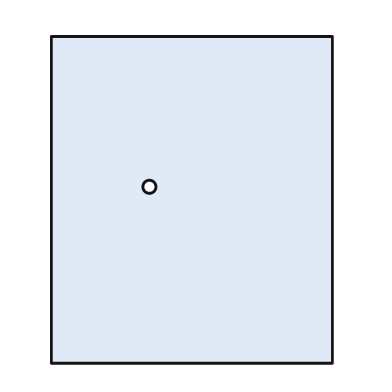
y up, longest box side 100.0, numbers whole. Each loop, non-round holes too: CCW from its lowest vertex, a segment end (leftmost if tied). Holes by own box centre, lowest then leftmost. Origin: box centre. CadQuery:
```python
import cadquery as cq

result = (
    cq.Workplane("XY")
    .moveTo(-43.0, -50.0)
    .lineTo(43.0, -50.0)
    .lineTo(43.0, 50.0)
    .lineTo(-43.0, 50.0)
    .close()
    .moveTo(-13.0, 4.0)
    .circle(2.0)
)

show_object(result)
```